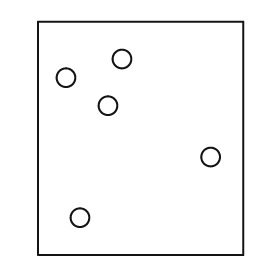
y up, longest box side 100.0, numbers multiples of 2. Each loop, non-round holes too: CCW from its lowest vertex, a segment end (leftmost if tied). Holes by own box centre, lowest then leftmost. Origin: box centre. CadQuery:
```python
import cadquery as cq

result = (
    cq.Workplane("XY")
    .moveTo(-44.0, -50.0)
    .lineTo(44.0, -50.0)
    .lineTo(44.0, 50.0)
    .lineTo(-44.0, 50.0)
    .close()
    .moveTo(-26.0, -34.0)
    .circle(4.0)
    .moveTo(30.0, -8.0)
    .circle(4.0)
    .moveTo(-14.0, 14.0)
    .circle(4.0)
    .moveTo(-32.0, 26.0)
    .circle(4.0)
    .moveTo(-8.0, 34.0)
    .circle(4.0)
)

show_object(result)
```